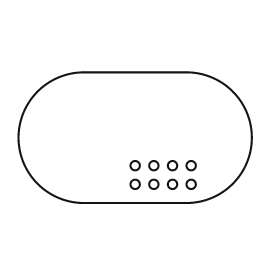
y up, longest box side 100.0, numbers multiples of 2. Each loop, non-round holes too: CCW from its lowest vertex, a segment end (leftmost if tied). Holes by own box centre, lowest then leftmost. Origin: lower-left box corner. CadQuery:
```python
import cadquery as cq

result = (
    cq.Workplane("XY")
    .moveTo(28.0, 0.0)
    .lineTo(72.0, 0.0)
    .threePointArc((100.0, 28.0), (72.0, 56.0))
    .lineTo(28.0, 56.0)
    .threePointArc((0.0, 28.0), (28.0, 0.0))
    .close()
    .moveTo(50.0, 8.0)
    .circle(2.0)
    .moveTo(58.0, 8.0)
    .circle(2.0)
    .moveTo(66.0, 8.0)
    .circle(2.0)
    .moveTo(74.0, 8.0)
    .circle(2.0)
    .moveTo(50.0, 16.0)
    .circle(2.0)
    .moveTo(58.0, 16.0)
    .circle(2.0)
    .moveTo(66.0, 16.0)
    .circle(2.0)
    .moveTo(74.0, 16.0)
    .circle(2.0)
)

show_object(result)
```